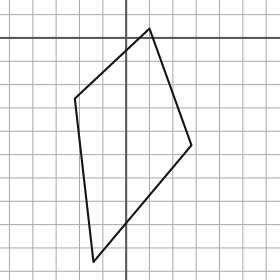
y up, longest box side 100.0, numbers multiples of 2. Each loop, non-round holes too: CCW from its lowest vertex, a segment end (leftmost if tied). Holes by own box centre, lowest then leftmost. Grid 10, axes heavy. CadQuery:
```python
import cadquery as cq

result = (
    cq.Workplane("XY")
    .moveTo(-14.0, -96.0)
    .lineTo(28.0, -46.0)
    .lineTo(10.0, 4.0)
    .lineTo(-22.0, -26.0)
    .close()
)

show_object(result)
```